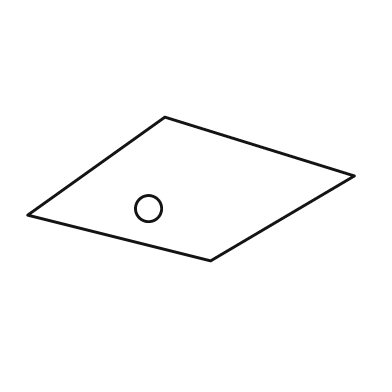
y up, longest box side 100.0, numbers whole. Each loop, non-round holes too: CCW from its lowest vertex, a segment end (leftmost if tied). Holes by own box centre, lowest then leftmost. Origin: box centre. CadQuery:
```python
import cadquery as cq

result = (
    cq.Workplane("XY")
    .moveTo(6.0, -22.0)
    .lineTo(50.0, 4.0)
    .lineTo(-8.0, 22.0)
    .lineTo(-50.0, -8.0)
    .close()
    .moveTo(-13.0, -6.0)
    .circle(4.0)
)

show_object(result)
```